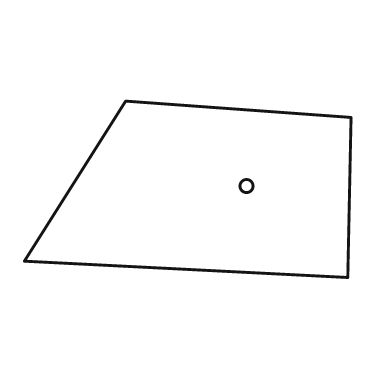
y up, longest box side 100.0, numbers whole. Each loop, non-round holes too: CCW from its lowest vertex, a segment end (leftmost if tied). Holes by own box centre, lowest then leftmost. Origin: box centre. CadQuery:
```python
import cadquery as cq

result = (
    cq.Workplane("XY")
    .moveTo(49.0, -27.0)
    .lineTo(50.0, 22.0)
    .lineTo(-19.0, 27.0)
    .lineTo(-50.0, -22.0)
    .close()
    .moveTo(18.0, 1.0)
    .circle(2.0)
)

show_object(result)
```